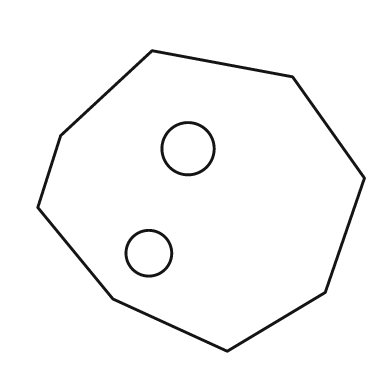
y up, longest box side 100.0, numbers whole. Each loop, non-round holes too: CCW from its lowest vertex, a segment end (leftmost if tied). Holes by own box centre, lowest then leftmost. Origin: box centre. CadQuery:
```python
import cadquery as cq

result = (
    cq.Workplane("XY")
    .moveTo(8.0, -46.0)
    .lineTo(38.0, -28.0)
    .lineTo(50.0, 7.0)
    .lineTo(28.0, 38.0)
    .lineTo(-15.0, 46.0)
    .lineTo(-43.0, 20.0)
    .lineTo(-50.0, -2.0)
    .lineTo(-27.0, -30.0)
    .close()
    .moveTo(-16.0, -16.0)
    .circle(7.0)
    .moveTo(-4.0, 16.0)
    .circle(8.0)
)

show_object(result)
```